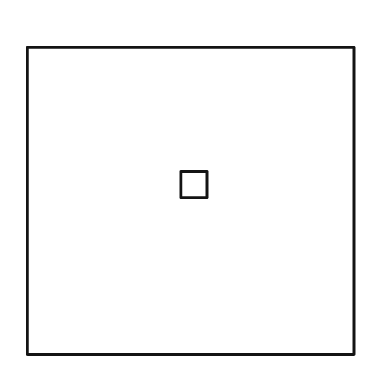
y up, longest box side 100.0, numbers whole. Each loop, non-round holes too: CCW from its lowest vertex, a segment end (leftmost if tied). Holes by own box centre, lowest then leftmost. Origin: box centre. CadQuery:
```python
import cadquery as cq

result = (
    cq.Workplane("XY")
    .moveTo(-50.0, -47.0)
    .lineTo(50.0, -47.0)
    .lineTo(50.0, 47.0)
    .lineTo(-50.0, 47.0)
    .close()
    .moveTo(-3.0, 1.0)
    .lineTo(5.0, 1.0)
    .lineTo(5.0, 9.0)
    .lineTo(-3.0, 9.0)
    .close()
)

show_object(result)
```